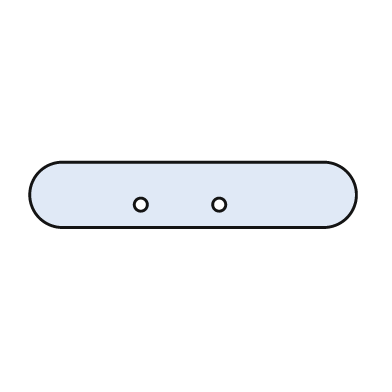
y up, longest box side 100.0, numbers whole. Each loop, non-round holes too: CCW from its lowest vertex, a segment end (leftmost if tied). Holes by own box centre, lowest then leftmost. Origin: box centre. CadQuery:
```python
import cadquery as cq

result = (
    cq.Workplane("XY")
    .moveTo(-40.0, -10.0)
    .lineTo(40.0, -10.0)
    .threePointArc((50.0, 0.0), (40.0, 10.0))
    .lineTo(-40.0, 10.0)
    .threePointArc((-50.0, 0.0), (-40.0, -10.0))
    .close()
    .moveTo(-16.0, -3.0)
    .circle(2.0)
    .moveTo(8.0, -3.0)
    .circle(2.0)
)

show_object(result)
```